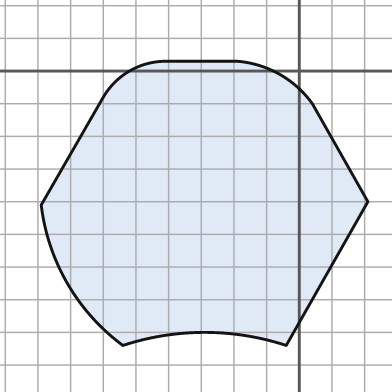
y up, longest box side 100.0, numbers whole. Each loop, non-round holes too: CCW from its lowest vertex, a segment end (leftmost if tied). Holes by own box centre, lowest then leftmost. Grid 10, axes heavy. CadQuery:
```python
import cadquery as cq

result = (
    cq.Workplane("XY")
    .moveTo(-54.0, -84.0)
    .threePointArc((-29.0, -80.0), (-4.0, -84.0))
    .lineTo(21.0, -40.0)
    .lineTo(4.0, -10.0)
    .threePointArc((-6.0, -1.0), (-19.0, 3.0))
    .lineTo(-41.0, 3.0)
    .threePointArc((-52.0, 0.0), (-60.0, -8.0))
    .lineTo(-79.0, -41.0)
    .threePointArc((-71.0, -65.0), (-54.0, -84.0))
    .close()
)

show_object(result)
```